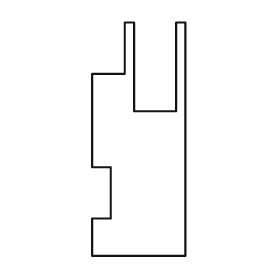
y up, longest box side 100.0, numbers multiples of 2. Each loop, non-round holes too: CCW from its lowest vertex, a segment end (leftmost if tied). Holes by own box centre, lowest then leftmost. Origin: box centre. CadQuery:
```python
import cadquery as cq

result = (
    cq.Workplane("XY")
    .moveTo(-20.0, -50.0)
    .lineTo(20.0, -50.0)
    .lineTo(20.0, 50.0)
    .lineTo(16.0, 50.0)
    .lineTo(16.0, 12.0)
    .lineTo(-2.0, 12.0)
    .lineTo(-2.0, 50.0)
    .lineTo(-6.0, 50.0)
    .lineTo(-6.0, 28.0)
    .lineTo(-20.0, 28.0)
    .lineTo(-20.0, -12.0)
    .lineTo(-12.0, -12.0)
    .lineTo(-12.0, -34.0)
    .lineTo(-20.0, -34.0)
    .close()
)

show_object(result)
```